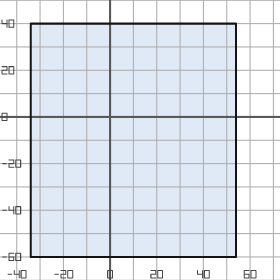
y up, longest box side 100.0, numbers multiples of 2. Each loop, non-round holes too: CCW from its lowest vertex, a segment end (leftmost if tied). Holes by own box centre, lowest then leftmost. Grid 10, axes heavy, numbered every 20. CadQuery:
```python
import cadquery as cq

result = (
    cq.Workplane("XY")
    .moveTo(-34.0, -60.0)
    .lineTo(54.0, -60.0)
    .lineTo(54.0, 40.0)
    .lineTo(-34.0, 40.0)
    .close()
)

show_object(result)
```